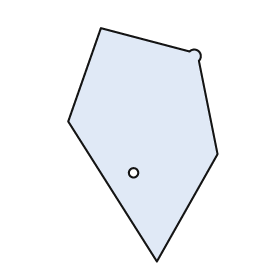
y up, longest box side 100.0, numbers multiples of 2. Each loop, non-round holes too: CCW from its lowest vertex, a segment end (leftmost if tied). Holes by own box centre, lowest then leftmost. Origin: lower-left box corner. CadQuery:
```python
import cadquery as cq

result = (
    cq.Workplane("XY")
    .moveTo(38.0, 0.0)
    .lineTo(64.0, 46.0)
    .lineTo(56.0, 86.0)
    .threePointArc((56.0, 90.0), (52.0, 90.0))
    .lineTo(14.0, 100.0)
    .lineTo(0.0, 60.0)
    .close()
    .moveTo(28.0, 38.0)
    .circle(2.0)
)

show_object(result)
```